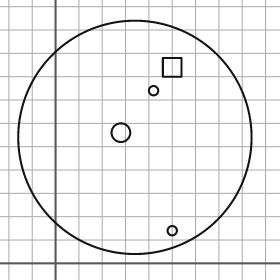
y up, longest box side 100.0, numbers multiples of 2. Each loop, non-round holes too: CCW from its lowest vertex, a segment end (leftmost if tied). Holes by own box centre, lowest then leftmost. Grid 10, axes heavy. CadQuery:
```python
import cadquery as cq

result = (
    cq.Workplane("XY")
    .moveTo(34.0, 54.0)
    .circle(50.0)
    .moveTo(50.0, 14.0)
    .circle(2.0)
    .moveTo(28.0, 56.0)
    .circle(4.0)
    .moveTo(42.0, 74.0)
    .circle(2.0)
    .moveTo(46.0, 80.0)
    .lineTo(54.0, 80.0)
    .lineTo(54.0, 88.0)
    .lineTo(46.0, 88.0)
    .close()
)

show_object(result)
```